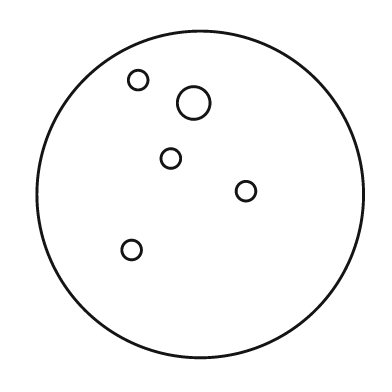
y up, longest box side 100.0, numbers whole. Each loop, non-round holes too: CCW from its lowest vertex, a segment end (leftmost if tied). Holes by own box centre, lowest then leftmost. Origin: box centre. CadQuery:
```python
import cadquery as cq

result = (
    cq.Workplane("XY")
    .moveTo(0.0, 0.0)
    .circle(50.0)
    .moveTo(-21.0, -17.0)
    .circle(3.0)
    .moveTo(14.0, 1.0)
    .circle(3.0)
    .moveTo(-9.0, 11.0)
    .circle(3.0)
    .moveTo(-2.0, 28.0)
    .circle(5.0)
    .moveTo(-19.0, 35.0)
    .circle(3.0)
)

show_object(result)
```